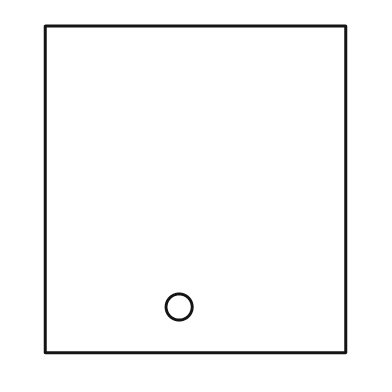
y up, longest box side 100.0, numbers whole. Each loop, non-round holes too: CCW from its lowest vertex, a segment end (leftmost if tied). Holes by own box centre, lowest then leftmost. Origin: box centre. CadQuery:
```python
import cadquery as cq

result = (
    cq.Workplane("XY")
    .moveTo(-46.0, -50.0)
    .lineTo(46.0, -50.0)
    .lineTo(46.0, 50.0)
    .lineTo(-46.0, 50.0)
    .close()
    .moveTo(-5.0, -36.0)
    .circle(4.0)
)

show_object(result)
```